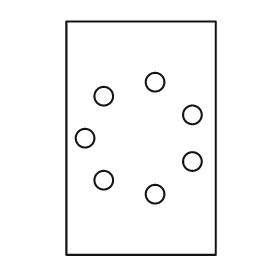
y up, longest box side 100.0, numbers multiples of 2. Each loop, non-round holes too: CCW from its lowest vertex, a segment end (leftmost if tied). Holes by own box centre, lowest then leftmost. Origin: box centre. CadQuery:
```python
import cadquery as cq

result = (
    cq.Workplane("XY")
    .moveTo(-32.0, -50.0)
    .lineTo(32.0, -50.0)
    .lineTo(32.0, 50.0)
    .lineTo(-32.0, 50.0)
    .close()
    .moveTo(6.0, -24.0)
    .circle(4.0)
    .moveTo(-16.0, -18.0)
    .circle(4.0)
    .moveTo(22.0, -10.0)
    .circle(4.0)
    .moveTo(-24.0, 0.0)
    .circle(4.0)
    .moveTo(22.0, 10.0)
    .circle(4.0)
    .moveTo(-16.0, 18.0)
    .circle(4.0)
    .moveTo(6.0, 24.0)
    .circle(4.0)
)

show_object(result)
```